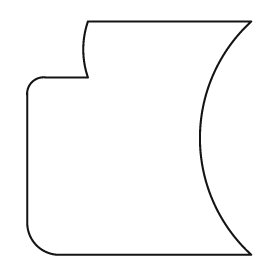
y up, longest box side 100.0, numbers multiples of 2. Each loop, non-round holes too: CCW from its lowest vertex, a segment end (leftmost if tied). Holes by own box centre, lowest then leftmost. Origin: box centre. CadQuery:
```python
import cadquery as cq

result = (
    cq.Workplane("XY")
    .moveTo(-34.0, -50.0)
    .lineTo(48.0, -50.0)
    .threePointArc((26.0, 0.0), (48.0, 50.0))
    .lineTo(-22.0, 50.0)
    .threePointArc((-24.0, 38.0), (-22.0, 26.0))
    .lineTo(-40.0, 26.0)
    .threePointArc((-46.0, 24.0), (-48.0, 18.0))
    .lineTo(-48.0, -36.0)
    .threePointArc((-44.0, -46.0), (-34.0, -50.0))
    .close()
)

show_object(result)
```